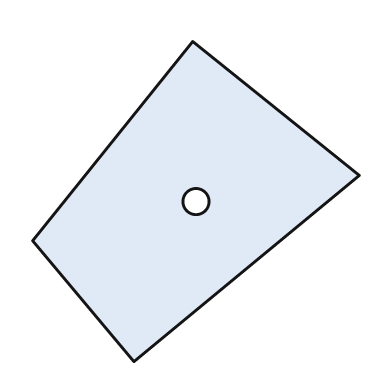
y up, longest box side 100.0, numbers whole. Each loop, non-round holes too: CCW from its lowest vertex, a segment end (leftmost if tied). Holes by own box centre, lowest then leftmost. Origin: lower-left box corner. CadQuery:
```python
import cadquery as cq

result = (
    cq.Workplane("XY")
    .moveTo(31.0, 0.0)
    .lineTo(100.0, 57.0)
    .lineTo(49.0, 98.0)
    .lineTo(0.0, 37.0)
    .close()
    .moveTo(50.0, 49.0)
    .circle(4.0)
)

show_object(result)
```